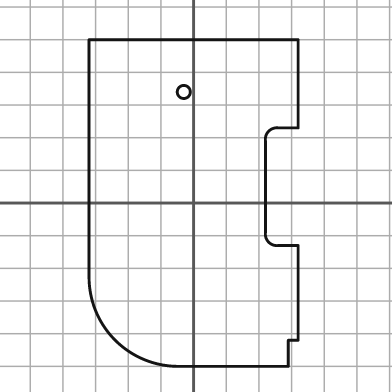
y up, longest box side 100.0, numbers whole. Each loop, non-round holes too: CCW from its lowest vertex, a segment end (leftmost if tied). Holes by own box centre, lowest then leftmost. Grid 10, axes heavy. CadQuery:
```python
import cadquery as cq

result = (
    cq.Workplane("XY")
    .moveTo(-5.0, -50.0)
    .lineTo(29.0, -50.0)
    .lineTo(29.0, -42.0)
    .lineTo(32.0, -42.0)
    .lineTo(32.0, -13.0)
    .lineTo(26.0, -13.0)
    .threePointArc((23.0, -12.0), (22.0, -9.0))
    .lineTo(22.0, 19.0)
    .threePointArc((23.0, 22.0), (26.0, 23.0))
    .lineTo(32.0, 23.0)
    .lineTo(32.0, 50.0)
    .lineTo(-32.0, 50.0)
    .lineTo(-32.0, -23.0)
    .threePointArc((-24.0, -42.0), (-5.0, -50.0))
    .close()
    .moveTo(-3.0, 34.0)
    .circle(2.0)
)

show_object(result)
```